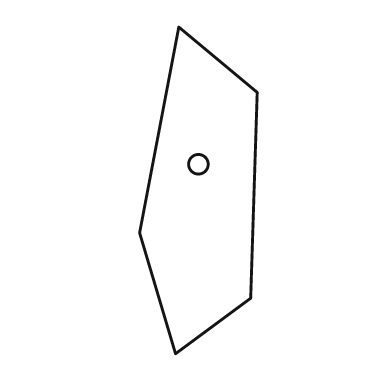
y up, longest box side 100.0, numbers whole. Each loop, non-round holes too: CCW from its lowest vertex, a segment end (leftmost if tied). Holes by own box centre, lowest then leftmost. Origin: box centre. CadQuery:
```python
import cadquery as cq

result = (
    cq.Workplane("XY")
    .moveTo(-7.0, -50.0)
    .lineTo(16.0, -33.0)
    .lineTo(18.0, 30.0)
    .lineTo(-6.0, 50.0)
    .lineTo(-18.0, -13.0)
    .close()
    .moveTo(0.0, 8.0)
    .circle(3.0)
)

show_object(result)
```